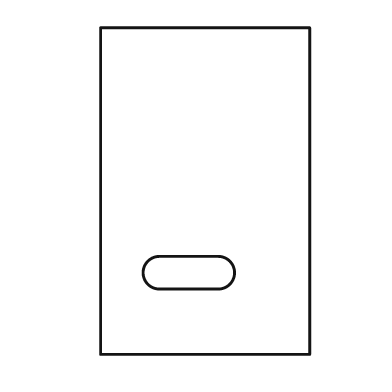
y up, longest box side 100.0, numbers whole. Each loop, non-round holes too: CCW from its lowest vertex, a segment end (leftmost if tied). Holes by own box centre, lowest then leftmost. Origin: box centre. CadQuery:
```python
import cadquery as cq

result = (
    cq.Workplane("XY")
    .moveTo(-32.0, -50.0)
    .lineTo(32.0, -50.0)
    .lineTo(32.0, 50.0)
    .lineTo(-32.0, 50.0)
    .close()
    .moveTo(-14.0, -30.0)
    .lineTo(4.0, -30.0)
    .threePointArc((9.0, -25.0), (4.0, -20.0))
    .lineTo(-14.0, -20.0)
    .threePointArc((-19.0, -25.0), (-14.0, -30.0))
    .close()
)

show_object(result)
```